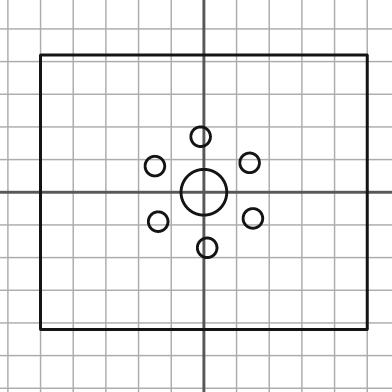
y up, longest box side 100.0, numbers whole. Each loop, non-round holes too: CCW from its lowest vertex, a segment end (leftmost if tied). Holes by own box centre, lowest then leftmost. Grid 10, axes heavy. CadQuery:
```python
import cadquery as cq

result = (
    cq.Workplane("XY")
    .moveTo(-50.0, -42.0)
    .lineTo(50.0, -42.0)
    .lineTo(50.0, 42.0)
    .lineTo(-50.0, 42.0)
    .close()
    .moveTo(1.0, -17.0)
    .circle(3.0)
    .moveTo(-14.0, -9.0)
    .circle(3.0)
    .moveTo(15.0, -8.0)
    .circle(3.0)
    .moveTo(0.0, 0.0)
    .circle(7.0)
    .moveTo(-15.0, 8.0)
    .circle(3.0)
    .moveTo(14.0, 9.0)
    .circle(3.0)
    .moveTo(-1.0, 17.0)
    .circle(3.0)
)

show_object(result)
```